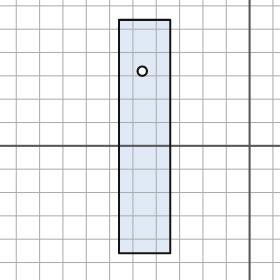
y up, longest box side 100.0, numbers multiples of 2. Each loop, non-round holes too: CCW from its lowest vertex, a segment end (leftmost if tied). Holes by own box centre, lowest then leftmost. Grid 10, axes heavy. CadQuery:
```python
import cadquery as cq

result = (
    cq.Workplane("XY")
    .moveTo(-56.0, -46.0)
    .lineTo(-34.0, -46.0)
    .lineTo(-34.0, 54.0)
    .lineTo(-56.0, 54.0)
    .close()
    .moveTo(-46.0, 32.0)
    .circle(2.0)
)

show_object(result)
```